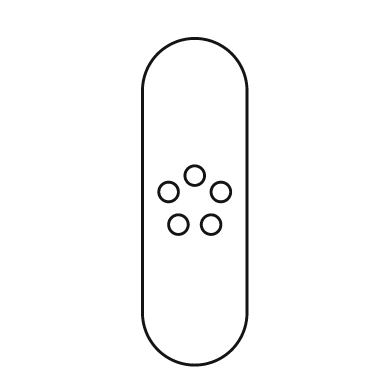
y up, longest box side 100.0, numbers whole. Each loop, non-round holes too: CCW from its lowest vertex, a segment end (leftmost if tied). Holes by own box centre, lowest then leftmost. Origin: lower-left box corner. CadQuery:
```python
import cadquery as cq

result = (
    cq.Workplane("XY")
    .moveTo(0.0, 16.0)
    .threePointArc((16.0, 0.0), (32.0, 16.0))
    .lineTo(32.0, 84.0)
    .threePointArc((16.0, 100.0), (0.0, 84.0))
    .close()
    .moveTo(11.0, 43.0)
    .circle(3.0)
    .moveTo(21.0, 43.0)
    .circle(3.0)
    .moveTo(8.0, 53.0)
    .circle(3.0)
    .moveTo(24.0, 53.0)
    .circle(3.0)
    .moveTo(16.0, 58.0)
    .circle(3.0)
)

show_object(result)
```